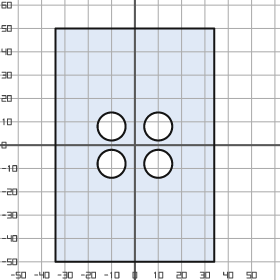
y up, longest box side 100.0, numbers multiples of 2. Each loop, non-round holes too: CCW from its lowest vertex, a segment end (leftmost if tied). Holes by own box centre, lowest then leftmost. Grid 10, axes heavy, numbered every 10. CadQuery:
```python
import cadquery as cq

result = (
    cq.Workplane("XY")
    .moveTo(-34.0, -50.0)
    .lineTo(34.0, -50.0)
    .lineTo(34.0, 50.0)
    .lineTo(-34.0, 50.0)
    .close()
    .moveTo(-10.0, -8.0)
    .circle(6.0)
    .moveTo(10.0, -8.0)
    .circle(6.0)
    .moveTo(-10.0, 8.0)
    .circle(6.0)
    .moveTo(10.0, 8.0)
    .circle(6.0)
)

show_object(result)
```